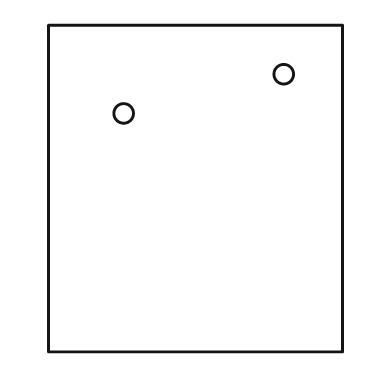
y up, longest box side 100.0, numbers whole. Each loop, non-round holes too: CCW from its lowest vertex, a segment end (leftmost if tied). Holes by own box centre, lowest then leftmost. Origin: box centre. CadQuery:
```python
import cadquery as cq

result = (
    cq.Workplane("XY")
    .moveTo(-45.0, -50.0)
    .lineTo(45.0, -50.0)
    .lineTo(45.0, 50.0)
    .lineTo(-45.0, 50.0)
    .close()
    .moveTo(-22.0, 23.0)
    .circle(3.0)
    .moveTo(27.0, 35.0)
    .circle(3.0)
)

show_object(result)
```